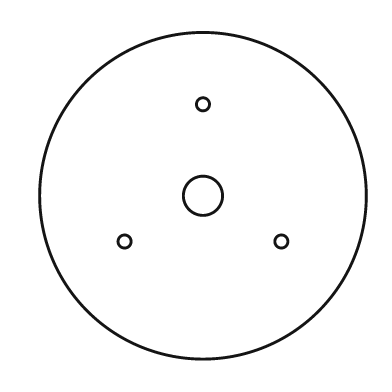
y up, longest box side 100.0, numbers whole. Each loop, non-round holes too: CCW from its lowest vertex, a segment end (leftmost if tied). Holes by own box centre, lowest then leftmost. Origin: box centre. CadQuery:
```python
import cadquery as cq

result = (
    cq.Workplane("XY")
    .moveTo(0.0, 0.0)
    .circle(50.0)
    .moveTo(-24.0, -14.0)
    .circle(2.0)
    .moveTo(24.0, -14.0)
    .circle(2.0)
    .moveTo(0.0, 0.0)
    .circle(6.0)
    .moveTo(0.0, 28.0)
    .circle(2.0)
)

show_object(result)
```